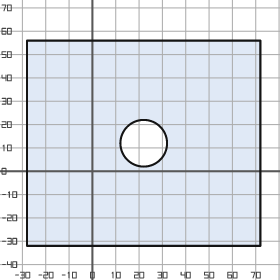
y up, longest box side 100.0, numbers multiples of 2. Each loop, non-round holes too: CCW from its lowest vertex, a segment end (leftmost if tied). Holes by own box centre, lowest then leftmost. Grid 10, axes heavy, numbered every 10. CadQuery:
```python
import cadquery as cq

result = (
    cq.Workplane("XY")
    .moveTo(-28.0, -32.0)
    .lineTo(72.0, -32.0)
    .lineTo(72.0, 56.0)
    .lineTo(-28.0, 56.0)
    .close()
    .moveTo(22.0, 12.0)
    .circle(10.0)
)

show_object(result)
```